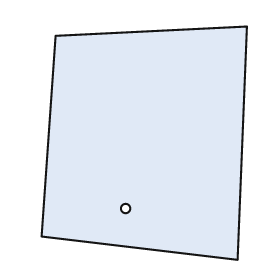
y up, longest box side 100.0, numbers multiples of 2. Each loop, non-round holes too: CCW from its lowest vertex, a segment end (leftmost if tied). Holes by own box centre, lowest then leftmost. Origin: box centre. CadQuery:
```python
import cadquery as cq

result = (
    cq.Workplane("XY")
    .moveTo(40.0, -50.0)
    .lineTo(44.0, 50.0)
    .lineTo(-38.0, 46.0)
    .lineTo(-44.0, -40.0)
    .close()
    .moveTo(-8.0, -28.0)
    .circle(2.0)
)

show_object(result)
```